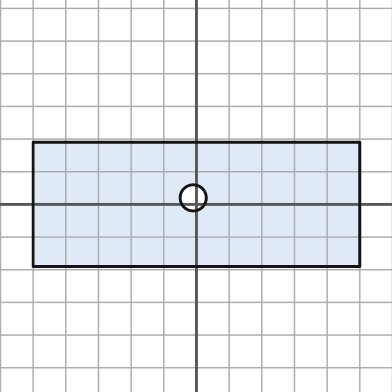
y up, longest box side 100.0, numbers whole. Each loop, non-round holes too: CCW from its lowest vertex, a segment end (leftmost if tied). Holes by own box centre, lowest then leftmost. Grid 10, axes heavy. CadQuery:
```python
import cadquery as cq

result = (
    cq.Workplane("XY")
    .moveTo(-50.0, -19.0)
    .lineTo(50.0, -19.0)
    .lineTo(50.0, 19.0)
    .lineTo(-50.0, 19.0)
    .close()
    .moveTo(-1.0, 2.0)
    .circle(4.0)
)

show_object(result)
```